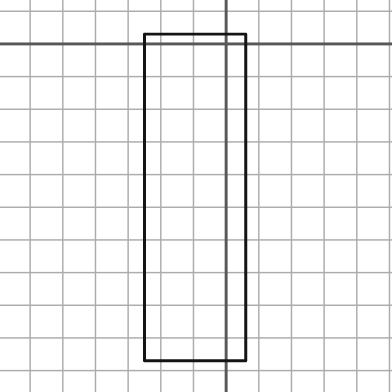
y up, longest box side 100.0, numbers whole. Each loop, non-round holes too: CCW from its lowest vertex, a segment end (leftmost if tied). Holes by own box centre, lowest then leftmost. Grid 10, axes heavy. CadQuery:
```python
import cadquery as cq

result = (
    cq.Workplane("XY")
    .moveTo(-25.0, -97.0)
    .lineTo(6.0, -97.0)
    .lineTo(6.0, 3.0)
    .lineTo(-25.0, 3.0)
    .close()
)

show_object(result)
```